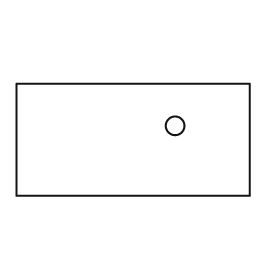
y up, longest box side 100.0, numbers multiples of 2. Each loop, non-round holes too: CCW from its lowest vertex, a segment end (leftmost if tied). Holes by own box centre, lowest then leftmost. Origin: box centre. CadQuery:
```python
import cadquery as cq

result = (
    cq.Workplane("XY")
    .moveTo(-50.0, -24.0)
    .lineTo(50.0, -24.0)
    .lineTo(50.0, 24.0)
    .lineTo(-50.0, 24.0)
    .close()
    .moveTo(18.0, 6.0)
    .circle(4.0)
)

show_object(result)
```